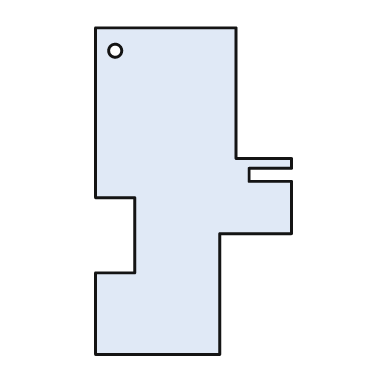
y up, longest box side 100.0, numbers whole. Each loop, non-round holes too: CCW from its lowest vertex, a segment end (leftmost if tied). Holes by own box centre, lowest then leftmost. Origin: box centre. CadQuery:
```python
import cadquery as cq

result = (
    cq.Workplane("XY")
    .moveTo(-30.0, -50.0)
    .lineTo(8.0, -50.0)
    .lineTo(8.0, -13.0)
    .lineTo(30.0, -13.0)
    .lineTo(30.0, 3.0)
    .lineTo(17.0, 3.0)
    .lineTo(17.0, 7.0)
    .lineTo(30.0, 7.0)
    .lineTo(30.0, 10.0)
    .lineTo(13.0, 10.0)
    .lineTo(13.0, 50.0)
    .lineTo(-30.0, 50.0)
    .lineTo(-30.0, -2.0)
    .lineTo(-18.0, -2.0)
    .lineTo(-18.0, -25.0)
    .lineTo(-30.0, -25.0)
    .close()
    .moveTo(-24.0, 43.0)
    .circle(2.0)
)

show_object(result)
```